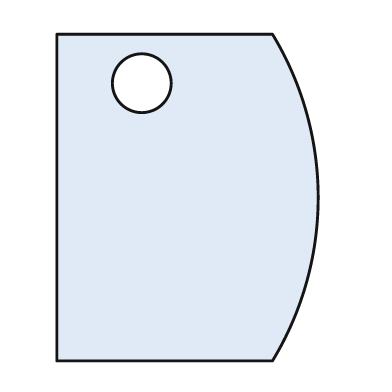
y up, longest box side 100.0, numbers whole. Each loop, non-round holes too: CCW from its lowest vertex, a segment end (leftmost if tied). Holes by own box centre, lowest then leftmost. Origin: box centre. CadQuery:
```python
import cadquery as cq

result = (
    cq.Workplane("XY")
    .moveTo(-40.0, -50.0)
    .lineTo(26.0, -50.0)
    .threePointArc((40.0, 0.0), (26.0, 50.0))
    .lineTo(-40.0, 50.0)
    .close()
    .moveTo(-14.0, 35.0)
    .circle(9.0)
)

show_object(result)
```